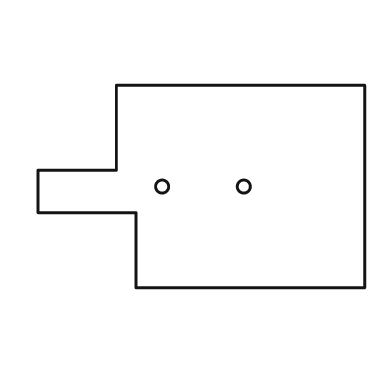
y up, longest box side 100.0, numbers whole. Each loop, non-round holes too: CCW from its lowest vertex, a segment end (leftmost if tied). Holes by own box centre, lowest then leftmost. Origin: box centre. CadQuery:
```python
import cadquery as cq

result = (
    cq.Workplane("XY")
    .moveTo(-20.0, -31.0)
    .lineTo(50.0, -31.0)
    .lineTo(50.0, 31.0)
    .lineTo(-26.0, 31.0)
    .lineTo(-26.0, 5.0)
    .lineTo(-50.0, 5.0)
    .lineTo(-50.0, -8.0)
    .lineTo(-20.0, -8.0)
    .close()
    .moveTo(-12.0, 0.0)
    .circle(2.0)
    .moveTo(13.0, 0.0)
    .circle(2.0)
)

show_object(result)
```